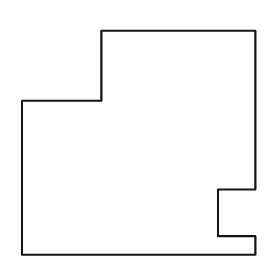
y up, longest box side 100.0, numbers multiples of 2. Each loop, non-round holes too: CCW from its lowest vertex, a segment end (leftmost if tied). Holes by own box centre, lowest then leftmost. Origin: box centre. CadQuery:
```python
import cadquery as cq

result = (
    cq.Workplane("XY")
    .moveTo(-50.0, -48.0)
    .lineTo(50.0, -48.0)
    .lineTo(50.0, -40.0)
    .lineTo(34.0, -40.0)
    .lineTo(34.0, -20.0)
    .lineTo(50.0, -20.0)
    .lineTo(50.0, 48.0)
    .lineTo(-16.0, 48.0)
    .lineTo(-16.0, 18.0)
    .lineTo(-50.0, 18.0)
    .close()
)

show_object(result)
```